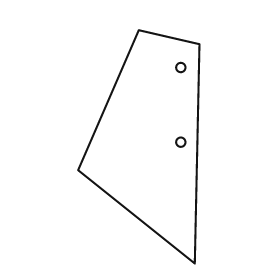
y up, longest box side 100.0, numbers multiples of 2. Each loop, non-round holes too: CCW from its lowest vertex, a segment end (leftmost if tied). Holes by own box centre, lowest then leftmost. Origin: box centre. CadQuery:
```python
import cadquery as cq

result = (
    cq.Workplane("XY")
    .moveTo(24.0, -50.0)
    .lineTo(26.0, 44.0)
    .lineTo(0.0, 50.0)
    .lineTo(-26.0, -10.0)
    .close()
    .moveTo(18.0, 2.0)
    .circle(2.0)
    .moveTo(18.0, 34.0)
    .circle(2.0)
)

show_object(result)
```